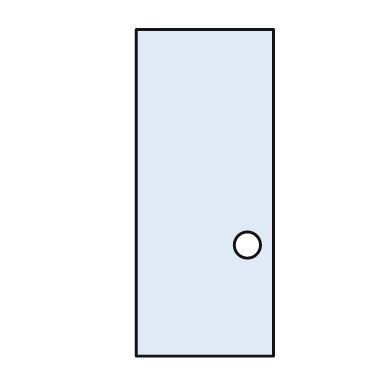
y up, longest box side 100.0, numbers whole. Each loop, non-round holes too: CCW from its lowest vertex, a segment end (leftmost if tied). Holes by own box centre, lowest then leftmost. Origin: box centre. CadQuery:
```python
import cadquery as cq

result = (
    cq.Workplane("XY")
    .moveTo(-21.0, -50.0)
    .lineTo(21.0, -50.0)
    .lineTo(21.0, 50.0)
    .lineTo(-21.0, 50.0)
    .close()
    .moveTo(13.0, -16.0)
    .circle(4.0)
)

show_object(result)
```